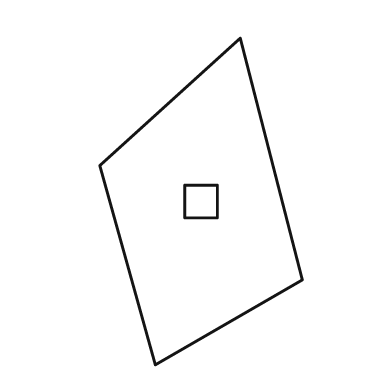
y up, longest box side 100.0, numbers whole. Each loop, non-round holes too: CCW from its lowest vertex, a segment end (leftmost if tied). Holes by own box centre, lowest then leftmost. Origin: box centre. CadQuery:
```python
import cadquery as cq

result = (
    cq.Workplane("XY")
    .moveTo(-14.0, -50.0)
    .lineTo(31.0, -24.0)
    .lineTo(12.0, 50.0)
    .lineTo(-31.0, 11.0)
    .close()
    .moveTo(-5.0, -5.0)
    .lineTo(5.0, -5.0)
    .lineTo(5.0, 5.0)
    .lineTo(-5.0, 5.0)
    .close()
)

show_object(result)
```